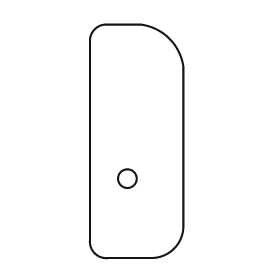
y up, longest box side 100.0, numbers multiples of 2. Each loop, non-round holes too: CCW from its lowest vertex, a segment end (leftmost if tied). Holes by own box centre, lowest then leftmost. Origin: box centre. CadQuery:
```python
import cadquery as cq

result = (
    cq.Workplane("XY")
    .moveTo(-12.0, -50.0)
    .lineTo(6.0, -50.0)
    .threePointArc((16.0, -46.0), (20.0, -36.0))
    .lineTo(20.0, 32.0)
    .threePointArc((14.0, 44.0), (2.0, 50.0))
    .lineTo(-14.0, 50.0)
    .threePointArc((-18.0, 48.0), (-20.0, 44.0))
    .lineTo(-20.0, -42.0)
    .threePointArc((-18.0, -48.0), (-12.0, -50.0))
    .close()
    .moveTo(-4.0, -16.0)
    .circle(4.0)
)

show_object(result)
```